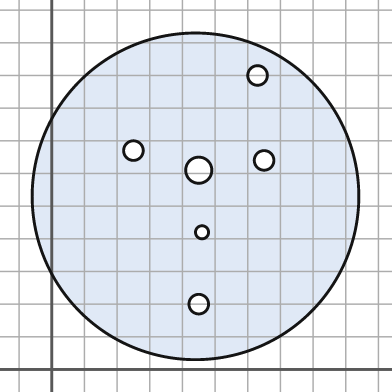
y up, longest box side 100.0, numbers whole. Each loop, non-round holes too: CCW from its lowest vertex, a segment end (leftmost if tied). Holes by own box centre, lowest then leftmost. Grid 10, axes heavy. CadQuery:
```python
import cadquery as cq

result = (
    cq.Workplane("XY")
    .moveTo(44.0, 53.0)
    .circle(50.0)
    .moveTo(45.0, 20.0)
    .circle(3.0)
    .moveTo(46.0, 42.0)
    .circle(2.0)
    .moveTo(45.0, 61.0)
    .circle(4.0)
    .moveTo(65.0, 64.0)
    .circle(3.0)
    .moveTo(25.0, 67.0)
    .circle(3.0)
    .moveTo(63.0, 90.0)
    .circle(3.0)
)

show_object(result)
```